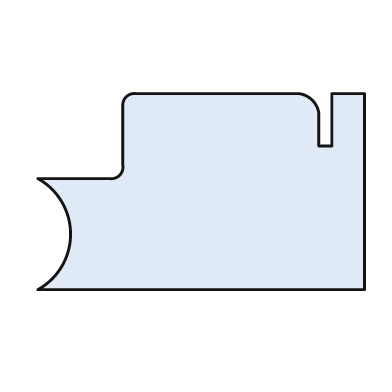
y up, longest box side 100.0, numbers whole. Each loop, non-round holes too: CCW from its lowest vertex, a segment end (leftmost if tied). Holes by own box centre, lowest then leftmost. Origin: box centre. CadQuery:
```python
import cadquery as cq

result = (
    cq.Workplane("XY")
    .moveTo(-50.0, -30.0)
    .lineTo(50.0, -30.0)
    .lineTo(50.0, 30.0)
    .lineTo(40.0, 30.0)
    .lineTo(40.0, 14.0)
    .lineTo(36.0, 14.0)
    .lineTo(36.0, 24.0)
    .threePointArc((34.0, 28.0), (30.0, 30.0))
    .lineTo(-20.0, 30.0)
    .threePointArc((-23.0, 29.0), (-24.0, 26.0))
    .lineTo(-24.0, 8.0)
    .threePointArc((-25.0, 5.0), (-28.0, 4.0))
    .lineTo(-50.0, 4.0)
    .threePointArc((-40.0, -13.0), (-50.0, -30.0))
    .close()
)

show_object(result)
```